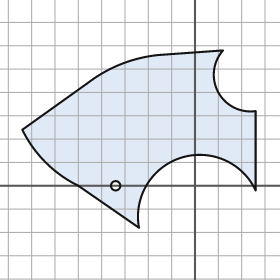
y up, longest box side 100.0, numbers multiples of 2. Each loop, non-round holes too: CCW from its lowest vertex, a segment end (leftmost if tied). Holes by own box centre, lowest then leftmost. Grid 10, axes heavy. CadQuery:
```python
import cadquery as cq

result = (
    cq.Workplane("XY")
    .moveTo(-24.0, -18.0)
    .threePointArc((-6.0, 12.0), (26.0, -2.0))
    .lineTo(26.0, 32.0)
    .threePointArc((10.0, 40.0), (12.0, 58.0))
    .lineTo(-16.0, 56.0)
    .threePointArc((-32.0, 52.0), (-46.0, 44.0))
    .lineTo(-74.0, 24.0)
    .threePointArc((-64.0, 10.0), (-50.0, 0.0))
    .close()
    .moveTo(-34.0, 0.0)
    .circle(2.0)
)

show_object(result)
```